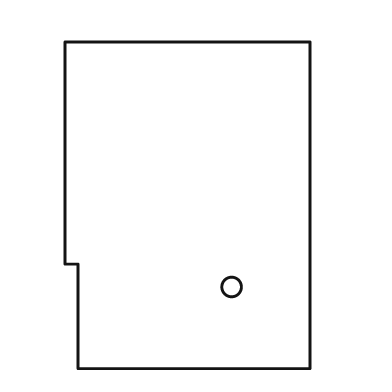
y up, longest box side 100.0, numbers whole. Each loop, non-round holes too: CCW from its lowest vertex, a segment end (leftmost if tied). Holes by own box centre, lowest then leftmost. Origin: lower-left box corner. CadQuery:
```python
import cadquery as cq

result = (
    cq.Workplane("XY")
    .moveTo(4.0, 0.0)
    .lineTo(75.0, 0.0)
    .lineTo(75.0, 100.0)
    .lineTo(0.0, 100.0)
    .lineTo(0.0, 32.0)
    .lineTo(4.0, 32.0)
    .close()
    .moveTo(51.0, 25.0)
    .circle(3.0)
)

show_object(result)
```